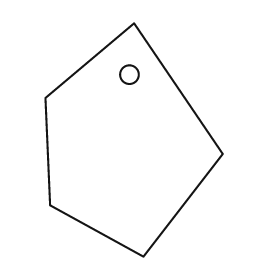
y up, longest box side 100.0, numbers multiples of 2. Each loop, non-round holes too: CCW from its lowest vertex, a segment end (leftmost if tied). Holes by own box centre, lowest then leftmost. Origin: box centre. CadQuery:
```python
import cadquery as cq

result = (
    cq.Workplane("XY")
    .moveTo(4.0, -50.0)
    .lineTo(38.0, -6.0)
    .lineTo(0.0, 50.0)
    .lineTo(-38.0, 18.0)
    .lineTo(-36.0, -28.0)
    .close()
    .moveTo(-2.0, 28.0)
    .circle(4.0)
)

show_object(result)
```